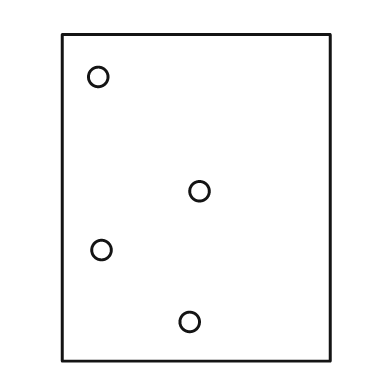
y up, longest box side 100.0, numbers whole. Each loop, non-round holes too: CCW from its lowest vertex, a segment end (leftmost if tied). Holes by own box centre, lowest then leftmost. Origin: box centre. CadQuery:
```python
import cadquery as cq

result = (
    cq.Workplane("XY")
    .moveTo(-41.0, -50.0)
    .lineTo(41.0, -50.0)
    .lineTo(41.0, 50.0)
    .lineTo(-41.0, 50.0)
    .close()
    .moveTo(-2.0, -38.0)
    .circle(3.0)
    .moveTo(-29.0, -16.0)
    .circle(3.0)
    .moveTo(1.0, 2.0)
    .circle(3.0)
    .moveTo(-30.0, 37.0)
    .circle(3.0)
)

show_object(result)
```